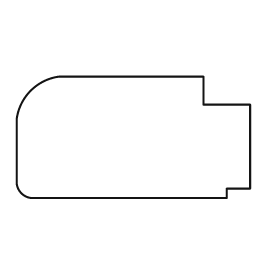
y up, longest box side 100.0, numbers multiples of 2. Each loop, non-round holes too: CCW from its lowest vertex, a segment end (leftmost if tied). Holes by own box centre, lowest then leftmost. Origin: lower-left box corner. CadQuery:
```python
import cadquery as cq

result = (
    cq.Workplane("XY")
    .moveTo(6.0, 0.0)
    .lineTo(90.0, 0.0)
    .lineTo(90.0, 4.0)
    .lineTo(100.0, 4.0)
    .lineTo(100.0, 40.0)
    .lineTo(80.0, 40.0)
    .lineTo(80.0, 52.0)
    .lineTo(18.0, 52.0)
    .threePointArc((6.0, 46.0), (0.0, 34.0))
    .lineTo(0.0, 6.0)
    .threePointArc((2.0, 2.0), (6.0, 0.0))
    .close()
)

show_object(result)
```